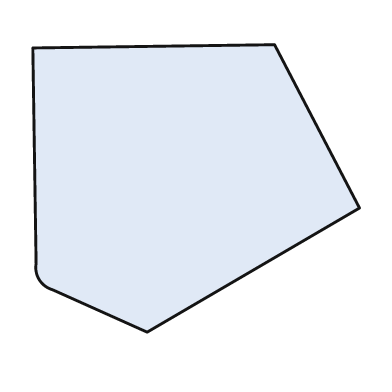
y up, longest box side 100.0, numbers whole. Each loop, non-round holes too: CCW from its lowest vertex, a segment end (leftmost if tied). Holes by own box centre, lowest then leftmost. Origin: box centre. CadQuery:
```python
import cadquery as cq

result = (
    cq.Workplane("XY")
    .moveTo(-15.0, -44.0)
    .lineTo(50.0, -6.0)
    .lineTo(24.0, 44.0)
    .lineTo(-50.0, 43.0)
    .lineTo(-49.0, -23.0)
    .threePointArc((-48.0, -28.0), (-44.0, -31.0))
    .close()
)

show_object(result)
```